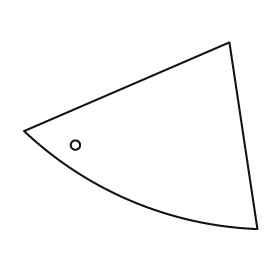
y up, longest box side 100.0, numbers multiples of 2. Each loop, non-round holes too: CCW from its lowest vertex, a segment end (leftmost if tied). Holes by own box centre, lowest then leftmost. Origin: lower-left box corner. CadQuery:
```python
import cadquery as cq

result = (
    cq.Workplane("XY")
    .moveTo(100.0, 0.0)
    .lineTo(88.0, 80.0)
    .lineTo(0.0, 42.0)
    .threePointArc((46.0, 12.0), (100.0, 0.0))
    .close()
    .moveTo(22.0, 36.0)
    .circle(2.0)
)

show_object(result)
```